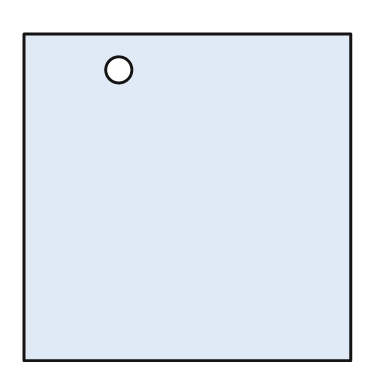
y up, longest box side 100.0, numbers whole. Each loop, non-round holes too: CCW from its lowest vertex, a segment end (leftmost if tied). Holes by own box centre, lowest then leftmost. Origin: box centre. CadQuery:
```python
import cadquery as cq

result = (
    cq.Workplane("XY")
    .moveTo(-50.0, -50.0)
    .lineTo(50.0, -50.0)
    .lineTo(50.0, 50.0)
    .lineTo(-50.0, 50.0)
    .close()
    .moveTo(-21.0, 39.0)
    .circle(4.0)
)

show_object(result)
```